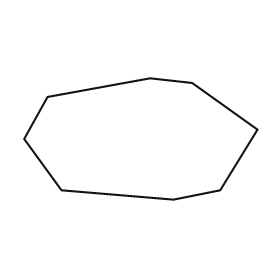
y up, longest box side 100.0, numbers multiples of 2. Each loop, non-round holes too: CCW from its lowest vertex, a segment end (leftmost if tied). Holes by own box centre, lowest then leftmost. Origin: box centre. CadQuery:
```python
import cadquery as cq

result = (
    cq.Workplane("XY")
    .moveTo(14.0, -26.0)
    .lineTo(34.0, -22.0)
    .lineTo(50.0, 4.0)
    .lineTo(22.0, 24.0)
    .lineTo(4.0, 26.0)
    .lineTo(-40.0, 18.0)
    .lineTo(-50.0, 0.0)
    .lineTo(-34.0, -22.0)
    .close()
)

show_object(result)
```